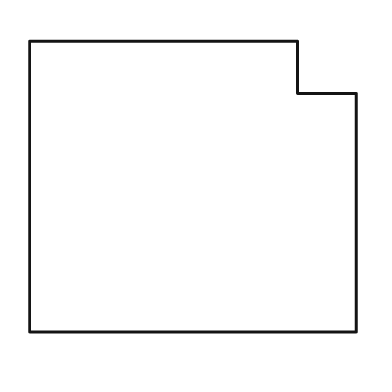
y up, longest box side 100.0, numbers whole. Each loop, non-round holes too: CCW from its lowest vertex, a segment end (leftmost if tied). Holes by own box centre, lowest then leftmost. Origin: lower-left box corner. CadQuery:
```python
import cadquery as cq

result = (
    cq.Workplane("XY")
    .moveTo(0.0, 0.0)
    .lineTo(100.0, 0.0)
    .lineTo(100.0, 73.0)
    .lineTo(82.0, 73.0)
    .lineTo(82.0, 89.0)
    .lineTo(0.0, 89.0)
    .close()
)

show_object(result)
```